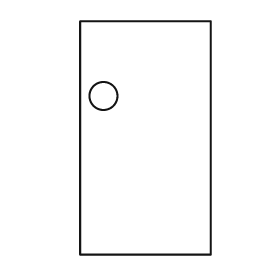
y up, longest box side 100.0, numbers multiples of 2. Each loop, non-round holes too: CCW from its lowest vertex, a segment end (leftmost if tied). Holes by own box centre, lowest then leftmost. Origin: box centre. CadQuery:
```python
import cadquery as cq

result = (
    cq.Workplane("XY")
    .moveTo(-28.0, -50.0)
    .lineTo(28.0, -50.0)
    .lineTo(28.0, 50.0)
    .lineTo(-28.0, 50.0)
    .close()
    .moveTo(-18.0, 18.0)
    .circle(6.0)
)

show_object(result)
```